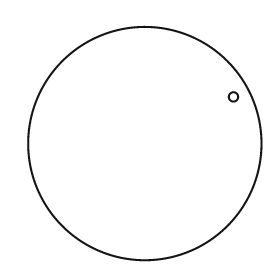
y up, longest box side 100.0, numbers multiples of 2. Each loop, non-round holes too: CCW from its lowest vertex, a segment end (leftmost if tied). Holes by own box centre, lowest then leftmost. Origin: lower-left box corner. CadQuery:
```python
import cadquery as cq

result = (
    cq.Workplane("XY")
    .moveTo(50.0, 50.0)
    .circle(50.0)
    .moveTo(88.0, 70.0)
    .circle(2.0)
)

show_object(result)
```